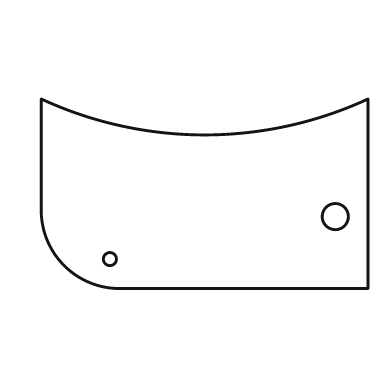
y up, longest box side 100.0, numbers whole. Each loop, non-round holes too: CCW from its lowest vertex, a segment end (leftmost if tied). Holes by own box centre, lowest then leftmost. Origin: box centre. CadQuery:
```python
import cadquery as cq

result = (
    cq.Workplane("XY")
    .moveTo(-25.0, -29.0)
    .lineTo(50.0, -29.0)
    .lineTo(50.0, 29.0)
    .threePointArc((0.0, 18.0), (-50.0, 29.0))
    .lineTo(-50.0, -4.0)
    .threePointArc((-43.0, -22.0), (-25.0, -29.0))
    .close()
    .moveTo(-29.0, -20.0)
    .circle(2.0)
    .moveTo(40.0, -7.0)
    .circle(4.0)
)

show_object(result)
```